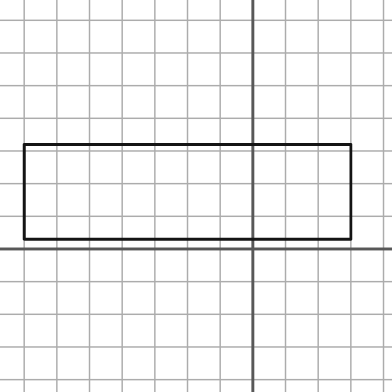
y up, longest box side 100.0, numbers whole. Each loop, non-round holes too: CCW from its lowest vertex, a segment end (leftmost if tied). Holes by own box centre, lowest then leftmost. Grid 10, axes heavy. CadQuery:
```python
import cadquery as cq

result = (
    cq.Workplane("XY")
    .moveTo(-70.0, 3.0)
    .lineTo(30.0, 3.0)
    .lineTo(30.0, 32.0)
    .lineTo(-70.0, 32.0)
    .close()
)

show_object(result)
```